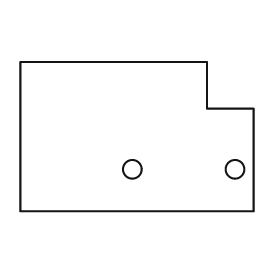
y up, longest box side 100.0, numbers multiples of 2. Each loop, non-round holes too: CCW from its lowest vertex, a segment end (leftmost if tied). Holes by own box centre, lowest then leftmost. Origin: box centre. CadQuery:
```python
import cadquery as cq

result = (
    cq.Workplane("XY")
    .moveTo(-50.0, -32.0)
    .lineTo(50.0, -32.0)
    .lineTo(50.0, 12.0)
    .lineTo(30.0, 12.0)
    .lineTo(30.0, 32.0)
    .lineTo(-50.0, 32.0)
    .close()
    .moveTo(-2.0, -14.0)
    .circle(4.0)
    .moveTo(42.0, -14.0)
    .circle(4.0)
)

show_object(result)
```